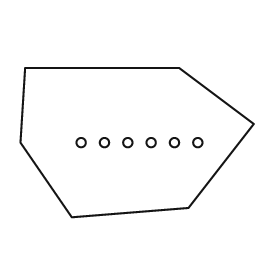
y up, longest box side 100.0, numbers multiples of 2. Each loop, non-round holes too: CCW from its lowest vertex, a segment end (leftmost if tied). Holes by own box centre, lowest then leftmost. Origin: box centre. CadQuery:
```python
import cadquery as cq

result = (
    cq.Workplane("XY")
    .moveTo(-28.0, -32.0)
    .lineTo(22.0, -28.0)
    .lineTo(50.0, 8.0)
    .lineTo(18.0, 32.0)
    .lineTo(-48.0, 32.0)
    .lineTo(-50.0, 0.0)
    .close()
    .moveTo(-24.0, 0.0)
    .circle(2.0)
    .moveTo(-14.0, 0.0)
    .circle(2.0)
    .moveTo(-4.0, 0.0)
    .circle(2.0)
    .moveTo(6.0, 0.0)
    .circle(2.0)
    .moveTo(16.0, 0.0)
    .circle(2.0)
    .moveTo(26.0, 0.0)
    .circle(2.0)
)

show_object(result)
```